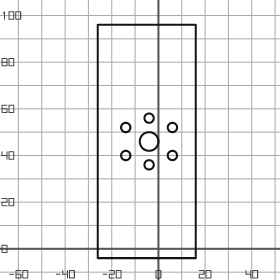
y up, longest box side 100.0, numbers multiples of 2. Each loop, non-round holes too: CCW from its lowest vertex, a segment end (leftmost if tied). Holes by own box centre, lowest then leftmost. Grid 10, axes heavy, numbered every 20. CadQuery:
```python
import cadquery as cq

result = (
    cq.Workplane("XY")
    .moveTo(-26.0, -4.0)
    .lineTo(16.0, -4.0)
    .lineTo(16.0, 96.0)
    .lineTo(-26.0, 96.0)
    .close()
    .moveTo(-4.0, 36.0)
    .circle(2.0)
    .moveTo(-14.0, 40.0)
    .circle(2.0)
    .moveTo(6.0, 40.0)
    .circle(2.0)
    .moveTo(-4.0, 46.0)
    .circle(4.0)
    .moveTo(-14.0, 52.0)
    .circle(2.0)
    .moveTo(6.0, 52.0)
    .circle(2.0)
    .moveTo(-4.0, 56.0)
    .circle(2.0)
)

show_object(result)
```